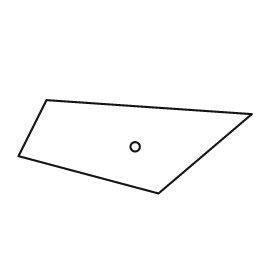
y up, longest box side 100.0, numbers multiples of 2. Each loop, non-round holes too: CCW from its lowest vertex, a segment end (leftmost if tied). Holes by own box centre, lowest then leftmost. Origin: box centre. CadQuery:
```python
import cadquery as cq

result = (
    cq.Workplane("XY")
    .moveTo(10.0, -20.0)
    .lineTo(50.0, 14.0)
    .lineTo(-38.0, 20.0)
    .lineTo(-50.0, -4.0)
    .close()
    .moveTo(0.0, 0.0)
    .circle(2.0)
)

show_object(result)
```